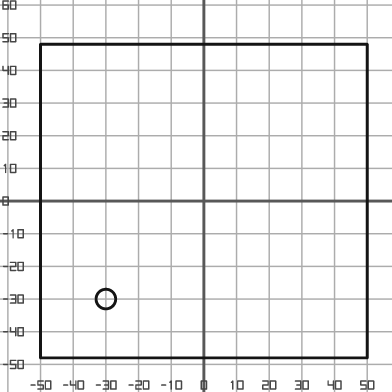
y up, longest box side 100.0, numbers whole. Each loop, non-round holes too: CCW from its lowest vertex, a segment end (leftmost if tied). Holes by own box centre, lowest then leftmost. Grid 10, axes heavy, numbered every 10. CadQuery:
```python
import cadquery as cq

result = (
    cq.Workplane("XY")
    .moveTo(-50.0, -48.0)
    .lineTo(50.0, -48.0)
    .lineTo(50.0, 48.0)
    .lineTo(-50.0, 48.0)
    .close()
    .moveTo(-30.0, -30.0)
    .circle(3.0)
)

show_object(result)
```